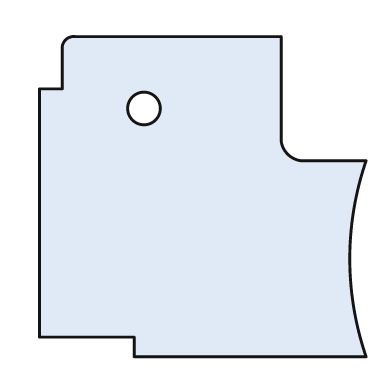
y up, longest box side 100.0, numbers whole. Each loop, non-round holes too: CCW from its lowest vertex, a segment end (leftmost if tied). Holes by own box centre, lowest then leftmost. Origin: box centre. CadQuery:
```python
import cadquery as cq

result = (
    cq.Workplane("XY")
    .moveTo(-21.0, -49.0)
    .lineTo(50.0, -49.0)
    .threePointArc((45.0, -19.0), (50.0, 11.0))
    .lineTo(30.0, 11.0)
    .threePointArc((26.0, 13.0), (24.0, 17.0))
    .lineTo(24.0, 49.0)
    .lineTo(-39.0, 49.0)
    .threePointArc((-42.0, 48.0), (-43.0, 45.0))
    .lineTo(-43.0, 33.0)
    .lineTo(-50.0, 33.0)
    .lineTo(-50.0, -43.0)
    .lineTo(-21.0, -43.0)
    .close()
    .moveTo(-18.0, 27.0)
    .circle(5.0)
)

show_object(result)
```